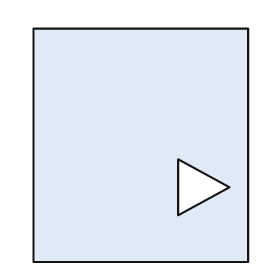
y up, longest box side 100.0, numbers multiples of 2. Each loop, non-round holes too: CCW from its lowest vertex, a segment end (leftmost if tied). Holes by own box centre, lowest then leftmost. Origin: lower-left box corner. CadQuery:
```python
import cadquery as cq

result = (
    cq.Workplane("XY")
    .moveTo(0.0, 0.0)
    .lineTo(92.0, 0.0)
    .lineTo(92.0, 100.0)
    .lineTo(0.0, 100.0)
    .close()
    .moveTo(62.0, 20.0)
    .lineTo(84.0, 32.0)
    .lineTo(62.0, 44.0)
    .close()
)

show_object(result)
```